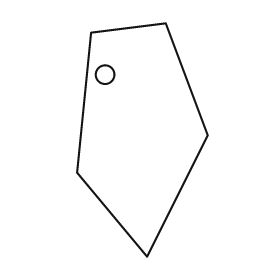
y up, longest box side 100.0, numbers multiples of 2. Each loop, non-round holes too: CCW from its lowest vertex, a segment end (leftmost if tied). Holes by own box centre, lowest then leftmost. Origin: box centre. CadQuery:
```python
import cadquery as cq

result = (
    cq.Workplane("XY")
    .moveTo(2.0, -50.0)
    .lineTo(28.0, 2.0)
    .lineTo(10.0, 50.0)
    .lineTo(-22.0, 46.0)
    .lineTo(-28.0, -14.0)
    .close()
    .moveTo(-16.0, 28.0)
    .circle(4.0)
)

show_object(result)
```